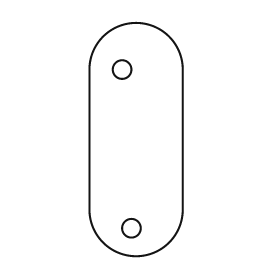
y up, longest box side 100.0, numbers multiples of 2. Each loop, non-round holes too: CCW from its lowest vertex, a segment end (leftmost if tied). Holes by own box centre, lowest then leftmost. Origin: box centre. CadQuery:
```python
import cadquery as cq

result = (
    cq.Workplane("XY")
    .moveTo(-20.0, -30.0)
    .threePointArc((0.0, -50.0), (20.0, -30.0))
    .lineTo(20.0, 30.0)
    .threePointArc((0.0, 50.0), (-20.0, 30.0))
    .close()
    .moveTo(-2.0, -38.0)
    .circle(4.0)
    .moveTo(-6.0, 30.0)
    .circle(4.0)
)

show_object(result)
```